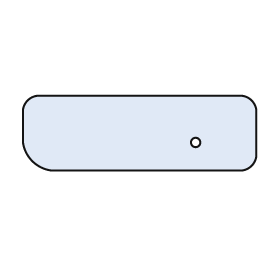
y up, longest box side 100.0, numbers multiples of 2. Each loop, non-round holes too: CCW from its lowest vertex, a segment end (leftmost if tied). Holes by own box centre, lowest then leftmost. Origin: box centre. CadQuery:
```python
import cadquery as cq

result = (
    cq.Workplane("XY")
    .moveTo(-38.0, -16.0)
    .lineTo(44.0, -16.0)
    .threePointArc((48.0, -14.0), (50.0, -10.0))
    .lineTo(50.0, 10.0)
    .threePointArc((48.0, 14.0), (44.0, 16.0))
    .lineTo(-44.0, 16.0)
    .threePointArc((-48.0, 14.0), (-50.0, 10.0))
    .lineTo(-50.0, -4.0)
    .threePointArc((-46.0, -12.0), (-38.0, -16.0))
    .close()
    .moveTo(24.0, -4.0)
    .circle(2.0)
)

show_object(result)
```